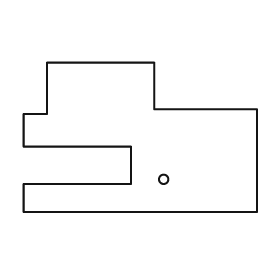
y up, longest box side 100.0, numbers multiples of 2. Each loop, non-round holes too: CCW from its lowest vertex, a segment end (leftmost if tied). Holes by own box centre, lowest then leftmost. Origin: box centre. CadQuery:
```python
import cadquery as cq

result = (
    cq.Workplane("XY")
    .moveTo(-50.0, -32.0)
    .lineTo(50.0, -32.0)
    .lineTo(50.0, 12.0)
    .lineTo(6.0, 12.0)
    .lineTo(6.0, 32.0)
    .lineTo(-40.0, 32.0)
    .lineTo(-40.0, 10.0)
    .lineTo(-50.0, 10.0)
    .lineTo(-50.0, -4.0)
    .lineTo(-4.0, -4.0)
    .lineTo(-4.0, -20.0)
    .lineTo(-50.0, -20.0)
    .close()
    .moveTo(10.0, -18.0)
    .circle(2.0)
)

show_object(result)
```